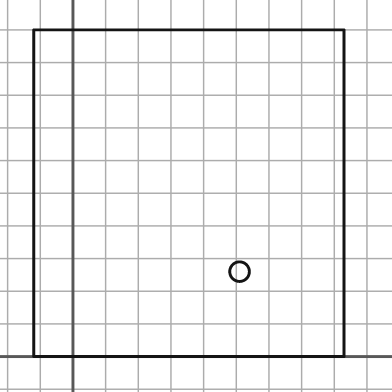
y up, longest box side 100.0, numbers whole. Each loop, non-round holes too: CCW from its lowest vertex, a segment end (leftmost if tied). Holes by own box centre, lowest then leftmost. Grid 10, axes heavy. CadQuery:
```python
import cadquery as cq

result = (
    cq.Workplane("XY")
    .moveTo(-12.0, 0.0)
    .lineTo(83.0, 0.0)
    .lineTo(83.0, 100.0)
    .lineTo(-12.0, 100.0)
    .close()
    .moveTo(51.0, 26.0)
    .circle(3.0)
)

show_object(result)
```